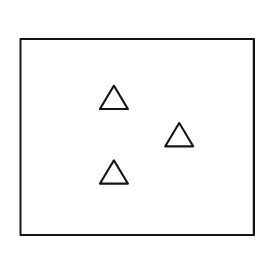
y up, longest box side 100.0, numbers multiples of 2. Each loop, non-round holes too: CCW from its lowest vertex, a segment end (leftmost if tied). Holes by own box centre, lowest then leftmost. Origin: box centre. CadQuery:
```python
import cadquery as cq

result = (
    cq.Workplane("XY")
    .moveTo(-50.0, -42.0)
    .lineTo(50.0, -42.0)
    .lineTo(50.0, 42.0)
    .lineTo(-50.0, 42.0)
    .close()
    .moveTo(-16.0, -20.0)
    .lineTo(-4.0, -20.0)
    .lineTo(-10.0, -10.0)
    .close()
    .moveTo(12.0, -4.0)
    .lineTo(24.0, -4.0)
    .lineTo(18.0, 6.0)
    .close()
    .moveTo(-16.0, 12.0)
    .lineTo(-4.0, 12.0)
    .lineTo(-10.0, 22.0)
    .close()
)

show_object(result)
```